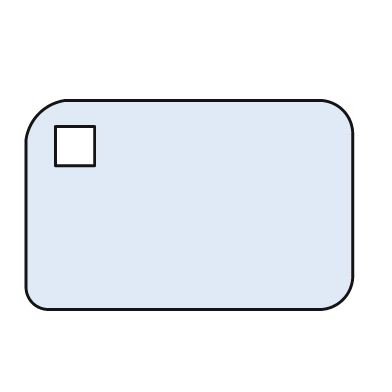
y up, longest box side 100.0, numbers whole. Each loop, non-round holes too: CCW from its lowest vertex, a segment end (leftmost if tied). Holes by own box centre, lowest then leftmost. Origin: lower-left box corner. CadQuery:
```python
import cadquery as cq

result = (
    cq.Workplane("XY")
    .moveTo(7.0, 0.0)
    .lineTo(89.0, 0.0)
    .threePointArc((97.0, 3.0), (100.0, 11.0))
    .lineTo(100.0, 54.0)
    .threePointArc((97.0, 61.0), (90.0, 64.0))
    .lineTo(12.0, 64.0)
    .threePointArc((4.0, 60.0), (0.0, 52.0))
    .lineTo(0.0, 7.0)
    .threePointArc((2.0, 2.0), (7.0, 0.0))
    .close()
    .moveTo(9.0, 44.0)
    .lineTo(21.0, 44.0)
    .lineTo(21.0, 56.0)
    .lineTo(9.0, 56.0)
    .close()
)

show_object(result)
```